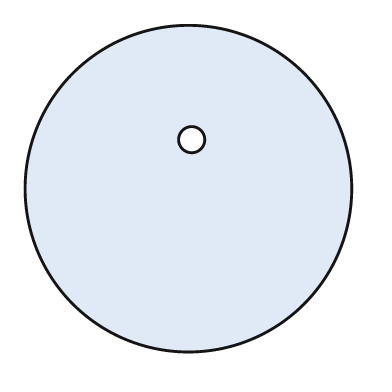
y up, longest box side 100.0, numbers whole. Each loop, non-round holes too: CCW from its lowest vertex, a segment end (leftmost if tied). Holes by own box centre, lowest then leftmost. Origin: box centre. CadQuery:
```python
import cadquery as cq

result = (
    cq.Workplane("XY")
    .moveTo(0.0, 0.0)
    .circle(50.0)
    .moveTo(1.0, 15.0)
    .circle(4.0)
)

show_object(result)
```